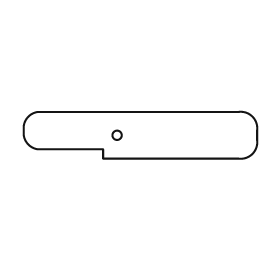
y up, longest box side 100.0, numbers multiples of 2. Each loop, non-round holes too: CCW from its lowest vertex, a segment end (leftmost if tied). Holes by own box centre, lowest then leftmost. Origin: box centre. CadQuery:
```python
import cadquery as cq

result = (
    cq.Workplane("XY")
    .moveTo(-16.0, -10.0)
    .lineTo(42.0, -10.0)
    .threePointArc((48.0, -8.0), (50.0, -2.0))
    .lineTo(50.0, 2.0)
    .threePointArc((48.0, 8.0), (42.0, 10.0))
    .lineTo(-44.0, 10.0)
    .threePointArc((-48.0, 8.0), (-50.0, 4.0))
    .lineTo(-50.0, 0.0)
    .threePointArc((-48.0, -4.0), (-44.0, -6.0))
    .lineTo(-16.0, -6.0)
    .close()
    .moveTo(-10.0, 0.0)
    .circle(2.0)
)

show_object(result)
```